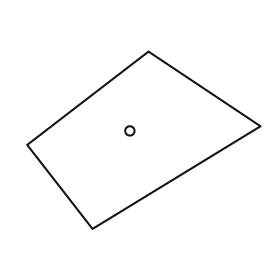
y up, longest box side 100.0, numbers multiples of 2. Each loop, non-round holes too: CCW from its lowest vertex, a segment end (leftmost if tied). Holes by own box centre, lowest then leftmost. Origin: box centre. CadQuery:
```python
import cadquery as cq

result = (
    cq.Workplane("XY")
    .moveTo(-22.0, -38.0)
    .lineTo(50.0, 6.0)
    .lineTo(2.0, 38.0)
    .lineTo(-50.0, -2.0)
    .close()
    .moveTo(-6.0, 4.0)
    .circle(2.0)
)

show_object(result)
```